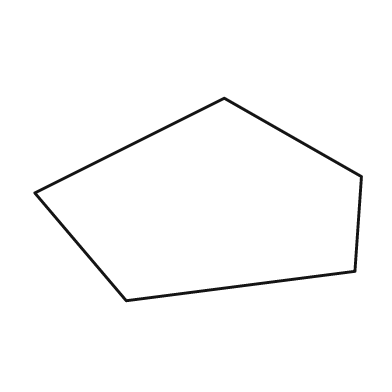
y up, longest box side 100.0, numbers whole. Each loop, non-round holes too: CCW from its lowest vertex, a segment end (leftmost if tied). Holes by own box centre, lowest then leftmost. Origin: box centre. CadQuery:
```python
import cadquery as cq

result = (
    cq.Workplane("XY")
    .moveTo(-22.0, -31.0)
    .lineTo(48.0, -22.0)
    .lineTo(50.0, 7.0)
    .lineTo(8.0, 31.0)
    .lineTo(-50.0, 2.0)
    .close()
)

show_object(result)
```